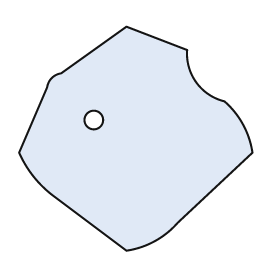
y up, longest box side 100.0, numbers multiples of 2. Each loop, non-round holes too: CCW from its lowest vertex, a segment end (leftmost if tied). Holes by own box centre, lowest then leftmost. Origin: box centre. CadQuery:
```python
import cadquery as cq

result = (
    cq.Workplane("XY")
    .moveTo(-4.0, -48.0)
    .threePointArc((8.0, -44.0), (18.0, -36.0))
    .lineTo(50.0, -6.0)
    .threePointArc((46.0, 6.0), (38.0, 16.0))
    .threePointArc((26.0, 24.0), (22.0, 38.0))
    .lineTo(-4.0, 48.0)
    .lineTo(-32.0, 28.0)
    .threePointArc((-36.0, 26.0), (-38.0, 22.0))
    .lineTo(-50.0, -6.0)
    .threePointArc((-44.0, -16.0), (-36.0, -24.0))
    .close()
    .moveTo(-18.0, 8.0)
    .circle(4.0)
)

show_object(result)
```